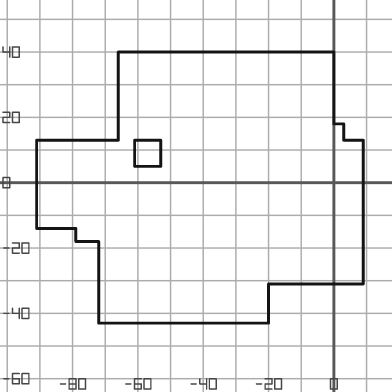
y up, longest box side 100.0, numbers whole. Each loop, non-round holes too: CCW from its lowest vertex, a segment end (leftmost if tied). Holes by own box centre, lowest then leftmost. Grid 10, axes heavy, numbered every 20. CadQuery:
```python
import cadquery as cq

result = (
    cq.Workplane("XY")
    .moveTo(-72.0, -43.0)
    .lineTo(-20.0, -43.0)
    .lineTo(-20.0, -31.0)
    .lineTo(9.0, -31.0)
    .lineTo(9.0, 13.0)
    .lineTo(3.0, 13.0)
    .lineTo(3.0, 18.0)
    .lineTo(0.0, 18.0)
    .lineTo(0.0, 40.0)
    .lineTo(-66.0, 40.0)
    .lineTo(-66.0, 13.0)
    .lineTo(-91.0, 13.0)
    .lineTo(-91.0, -14.0)
    .lineTo(-79.0, -14.0)
    .lineTo(-79.0, -18.0)
    .lineTo(-72.0, -18.0)
    .close()
    .moveTo(-61.0, 5.0)
    .lineTo(-53.0, 5.0)
    .lineTo(-53.0, 13.0)
    .lineTo(-61.0, 13.0)
    .close()
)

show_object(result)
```